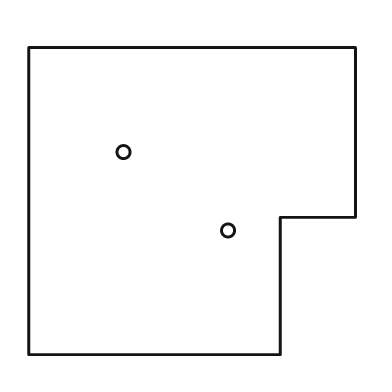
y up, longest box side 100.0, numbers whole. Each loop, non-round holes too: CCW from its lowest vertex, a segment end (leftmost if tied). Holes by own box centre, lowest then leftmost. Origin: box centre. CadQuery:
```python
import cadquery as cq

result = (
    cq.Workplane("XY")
    .moveTo(-50.0, -47.0)
    .lineTo(27.0, -47.0)
    .lineTo(27.0, -5.0)
    .lineTo(50.0, -5.0)
    .lineTo(50.0, 47.0)
    .lineTo(-50.0, 47.0)
    .close()
    .moveTo(11.0, -9.0)
    .circle(2.0)
    .moveTo(-21.0, 15.0)
    .circle(2.0)
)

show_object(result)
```